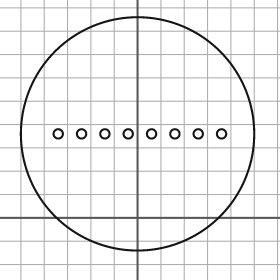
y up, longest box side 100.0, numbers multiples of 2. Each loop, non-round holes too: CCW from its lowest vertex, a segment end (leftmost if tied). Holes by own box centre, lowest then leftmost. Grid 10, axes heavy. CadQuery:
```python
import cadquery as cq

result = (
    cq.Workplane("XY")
    .moveTo(0.0, 36.0)
    .circle(50.0)
    .moveTo(-34.0, 36.0)
    .circle(2.0)
    .moveTo(-24.0, 36.0)
    .circle(2.0)
    .moveTo(-14.0, 36.0)
    .circle(2.0)
    .moveTo(-4.0, 36.0)
    .circle(2.0)
    .moveTo(6.0, 36.0)
    .circle(2.0)
    .moveTo(16.0, 36.0)
    .circle(2.0)
    .moveTo(26.0, 36.0)
    .circle(2.0)
    .moveTo(36.0, 36.0)
    .circle(2.0)
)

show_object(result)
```